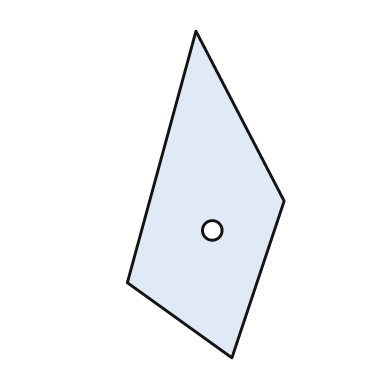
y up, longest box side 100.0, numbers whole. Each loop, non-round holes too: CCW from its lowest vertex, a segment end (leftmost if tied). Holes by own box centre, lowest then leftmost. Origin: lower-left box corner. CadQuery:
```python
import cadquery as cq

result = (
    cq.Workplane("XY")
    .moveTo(32.0, 0.0)
    .lineTo(48.0, 48.0)
    .lineTo(21.0, 100.0)
    .lineTo(0.0, 23.0)
    .close()
    .moveTo(26.0, 39.0)
    .circle(3.0)
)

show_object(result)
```